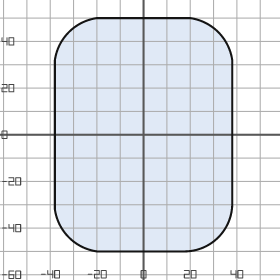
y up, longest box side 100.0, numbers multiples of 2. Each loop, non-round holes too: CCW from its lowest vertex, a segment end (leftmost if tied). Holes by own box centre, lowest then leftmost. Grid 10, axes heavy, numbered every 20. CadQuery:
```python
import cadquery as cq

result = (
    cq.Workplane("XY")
    .moveTo(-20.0, -50.0)
    .lineTo(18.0, -50.0)
    .threePointArc((32.0, -44.0), (38.0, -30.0))
    .lineTo(38.0, 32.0)
    .threePointArc((32.0, 44.0), (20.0, 50.0))
    .lineTo(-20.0, 50.0)
    .threePointArc((-32.0, 44.0), (-38.0, 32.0))
    .lineTo(-38.0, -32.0)
    .threePointArc((-32.0, -44.0), (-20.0, -50.0))
    .close()
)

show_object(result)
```